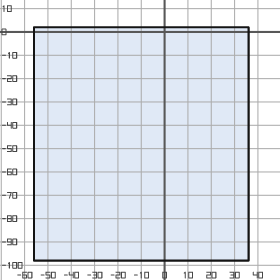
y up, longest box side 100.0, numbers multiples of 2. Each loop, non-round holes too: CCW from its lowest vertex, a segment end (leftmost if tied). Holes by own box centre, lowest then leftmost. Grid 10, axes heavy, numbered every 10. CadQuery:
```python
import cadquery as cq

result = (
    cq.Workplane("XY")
    .moveTo(-56.0, -98.0)
    .lineTo(36.0, -98.0)
    .lineTo(36.0, 2.0)
    .lineTo(-56.0, 2.0)
    .close()
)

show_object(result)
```